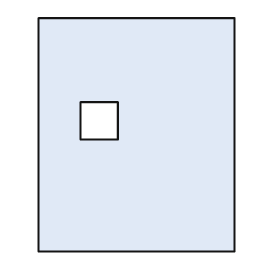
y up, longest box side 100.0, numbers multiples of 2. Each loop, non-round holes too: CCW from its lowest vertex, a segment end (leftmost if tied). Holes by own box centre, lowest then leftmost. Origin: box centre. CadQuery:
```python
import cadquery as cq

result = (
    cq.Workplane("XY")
    .moveTo(-42.0, -50.0)
    .lineTo(42.0, -50.0)
    .lineTo(42.0, 50.0)
    .lineTo(-42.0, 50.0)
    .close()
    .moveTo(-24.0, -2.0)
    .lineTo(-8.0, -2.0)
    .lineTo(-8.0, 14.0)
    .lineTo(-24.0, 14.0)
    .close()
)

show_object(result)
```